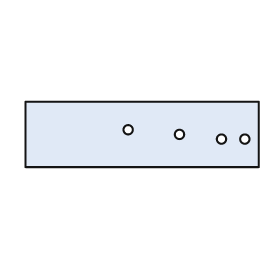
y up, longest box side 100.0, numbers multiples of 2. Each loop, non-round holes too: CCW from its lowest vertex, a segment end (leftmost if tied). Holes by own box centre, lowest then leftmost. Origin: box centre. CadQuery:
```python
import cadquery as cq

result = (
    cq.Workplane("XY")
    .moveTo(-50.0, -14.0)
    .lineTo(50.0, -14.0)
    .lineTo(50.0, 14.0)
    .lineTo(-50.0, 14.0)
    .close()
    .moveTo(34.0, -2.0)
    .circle(2.0)
    .moveTo(44.0, -2.0)
    .circle(2.0)
    .moveTo(16.0, 0.0)
    .circle(2.0)
    .moveTo(-6.0, 2.0)
    .circle(2.0)
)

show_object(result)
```